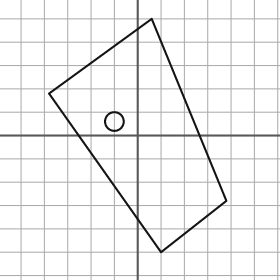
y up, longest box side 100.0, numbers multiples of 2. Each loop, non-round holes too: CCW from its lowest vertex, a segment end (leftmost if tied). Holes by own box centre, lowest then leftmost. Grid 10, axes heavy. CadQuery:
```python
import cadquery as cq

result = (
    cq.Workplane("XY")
    .moveTo(10.0, -50.0)
    .lineTo(38.0, -28.0)
    .lineTo(6.0, 50.0)
    .lineTo(-38.0, 18.0)
    .close()
    .moveTo(-10.0, 6.0)
    .circle(4.0)
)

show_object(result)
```